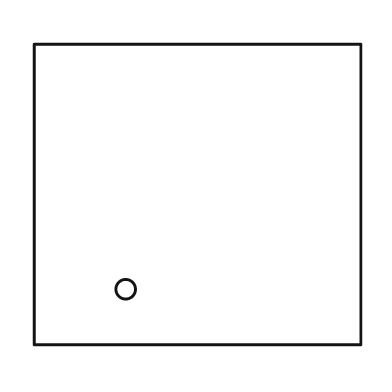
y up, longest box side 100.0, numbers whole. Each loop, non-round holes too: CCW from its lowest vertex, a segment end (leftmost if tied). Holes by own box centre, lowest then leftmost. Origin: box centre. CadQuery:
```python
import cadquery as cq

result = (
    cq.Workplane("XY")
    .moveTo(-50.0, -46.0)
    .lineTo(50.0, -46.0)
    .lineTo(50.0, 46.0)
    .lineTo(-50.0, 46.0)
    .close()
    .moveTo(-22.0, -29.0)
    .circle(3.0)
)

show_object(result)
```